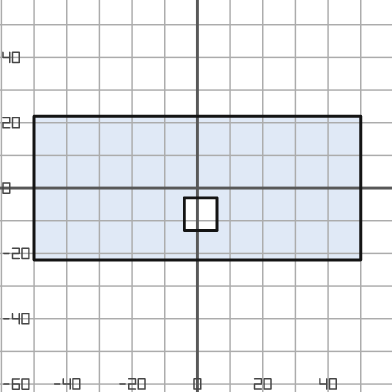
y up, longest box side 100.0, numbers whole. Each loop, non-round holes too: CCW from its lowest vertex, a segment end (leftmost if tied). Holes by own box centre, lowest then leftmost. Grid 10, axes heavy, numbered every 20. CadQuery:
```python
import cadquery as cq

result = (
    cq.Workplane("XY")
    .moveTo(-50.0, -22.0)
    .lineTo(50.0, -22.0)
    .lineTo(50.0, 22.0)
    .lineTo(-50.0, 22.0)
    .close()
    .moveTo(-4.0, -13.0)
    .lineTo(6.0, -13.0)
    .lineTo(6.0, -3.0)
    .lineTo(-4.0, -3.0)
    .close()
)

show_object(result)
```